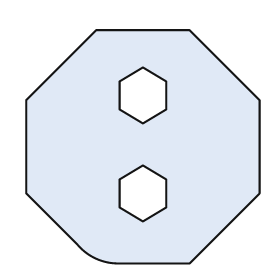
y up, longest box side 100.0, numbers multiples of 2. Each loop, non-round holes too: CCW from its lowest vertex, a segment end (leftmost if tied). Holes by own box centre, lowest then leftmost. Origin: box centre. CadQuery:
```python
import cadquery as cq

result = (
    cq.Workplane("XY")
    .moveTo(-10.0, -50.0)
    .lineTo(20.0, -50.0)
    .lineTo(50.0, -20.0)
    .lineTo(50.0, 20.0)
    .lineTo(20.0, 50.0)
    .lineTo(-20.0, 50.0)
    .lineTo(-50.0, 20.0)
    .lineTo(-50.0, -20.0)
    .lineTo(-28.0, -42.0)
    .threePointArc((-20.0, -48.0), (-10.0, -50.0))
    .close()
    .moveTo(0.0, -32.0)
    .lineTo(10.0, -26.0)
    .lineTo(10.0, -14.0)
    .lineTo(0.0, -8.0)
    .lineTo(-10.0, -14.0)
    .lineTo(-10.0, -26.0)
    .close()
    .moveTo(0.0, 10.0)
    .lineTo(10.0, 16.0)
    .lineTo(10.0, 28.0)
    .lineTo(0.0, 34.0)
    .lineTo(-10.0, 28.0)
    .lineTo(-10.0, 16.0)
    .close()
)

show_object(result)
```